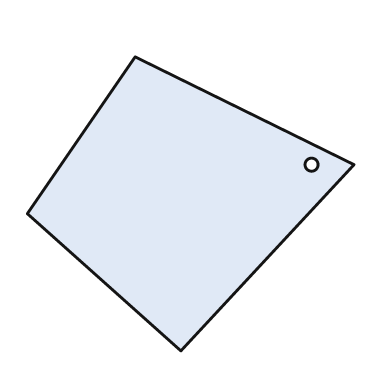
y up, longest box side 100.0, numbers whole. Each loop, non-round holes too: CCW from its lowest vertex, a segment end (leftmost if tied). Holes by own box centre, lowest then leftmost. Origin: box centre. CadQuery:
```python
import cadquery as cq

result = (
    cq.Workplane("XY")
    .moveTo(-3.0, -45.0)
    .lineTo(50.0, 12.0)
    .lineTo(-17.0, 45.0)
    .lineTo(-50.0, -3.0)
    .close()
    .moveTo(37.0, 12.0)
    .circle(2.0)
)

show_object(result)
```